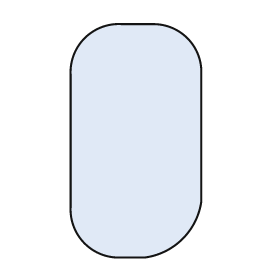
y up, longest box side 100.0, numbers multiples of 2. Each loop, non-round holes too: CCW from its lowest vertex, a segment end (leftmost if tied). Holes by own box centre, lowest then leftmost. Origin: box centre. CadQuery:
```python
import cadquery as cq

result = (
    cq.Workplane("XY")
    .moveTo(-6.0, -50.0)
    .lineTo(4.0, -50.0)
    .threePointArc((20.0, -42.0), (28.0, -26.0))
    .lineTo(28.0, 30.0)
    .threePointArc((22.0, 44.0), (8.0, 50.0))
    .lineTo(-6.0, 50.0)
    .threePointArc((-22.0, 44.0), (-28.0, 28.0))
    .lineTo(-28.0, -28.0)
    .threePointArc((-22.0, -44.0), (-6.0, -50.0))
    .close()
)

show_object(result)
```